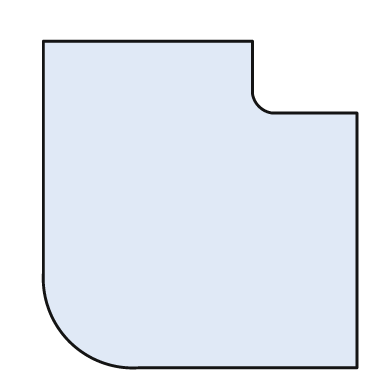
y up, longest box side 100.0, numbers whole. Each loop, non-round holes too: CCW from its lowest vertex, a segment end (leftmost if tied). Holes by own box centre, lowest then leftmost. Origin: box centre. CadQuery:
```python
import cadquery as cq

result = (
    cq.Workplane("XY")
    .moveTo(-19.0, -50.0)
    .lineTo(48.0, -50.0)
    .lineTo(48.0, 28.0)
    .lineTo(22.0, 28.0)
    .threePointArc((18.0, 30.0), (16.0, 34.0))
    .lineTo(16.0, 50.0)
    .lineTo(-48.0, 50.0)
    .lineTo(-48.0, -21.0)
    .threePointArc((-40.0, -42.0), (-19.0, -50.0))
    .close()
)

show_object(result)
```